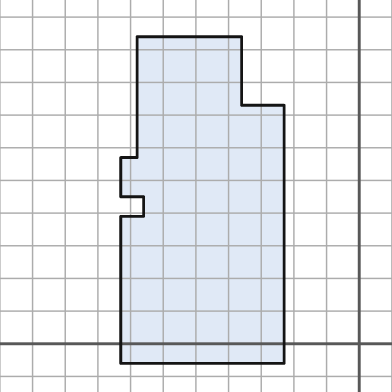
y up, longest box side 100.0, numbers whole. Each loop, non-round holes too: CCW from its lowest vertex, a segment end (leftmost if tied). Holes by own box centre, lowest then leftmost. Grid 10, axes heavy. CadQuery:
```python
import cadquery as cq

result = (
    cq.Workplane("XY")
    .moveTo(-73.0, -6.0)
    .lineTo(-23.0, -6.0)
    .lineTo(-23.0, 73.0)
    .lineTo(-36.0, 73.0)
    .lineTo(-36.0, 94.0)
    .lineTo(-68.0, 94.0)
    .lineTo(-68.0, 57.0)
    .lineTo(-73.0, 57.0)
    .lineTo(-73.0, 45.0)
    .lineTo(-66.0, 45.0)
    .lineTo(-66.0, 39.0)
    .lineTo(-73.0, 39.0)
    .close()
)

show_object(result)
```